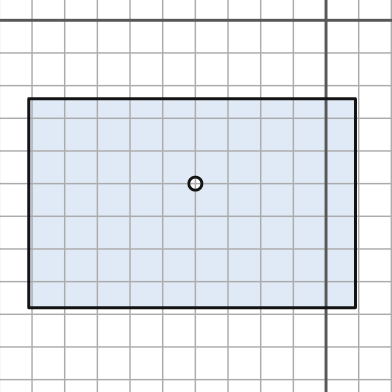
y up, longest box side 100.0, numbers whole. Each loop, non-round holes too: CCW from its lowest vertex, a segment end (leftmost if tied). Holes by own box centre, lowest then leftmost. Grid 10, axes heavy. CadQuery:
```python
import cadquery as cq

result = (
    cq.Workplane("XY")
    .moveTo(-91.0, -88.0)
    .lineTo(9.0, -88.0)
    .lineTo(9.0, -24.0)
    .lineTo(-91.0, -24.0)
    .close()
    .moveTo(-40.0, -50.0)
    .circle(2.0)
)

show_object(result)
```